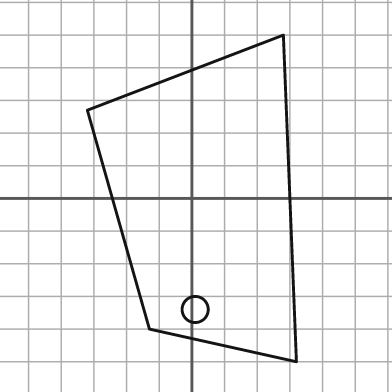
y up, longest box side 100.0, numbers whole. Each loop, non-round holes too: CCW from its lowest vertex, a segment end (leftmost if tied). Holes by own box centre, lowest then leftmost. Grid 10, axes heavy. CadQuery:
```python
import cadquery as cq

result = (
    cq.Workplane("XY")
    .moveTo(32.0, -50.0)
    .lineTo(28.0, 50.0)
    .lineTo(-32.0, 27.0)
    .lineTo(-13.0, -40.0)
    .close()
    .moveTo(1.0, -34.0)
    .circle(4.0)
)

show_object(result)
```